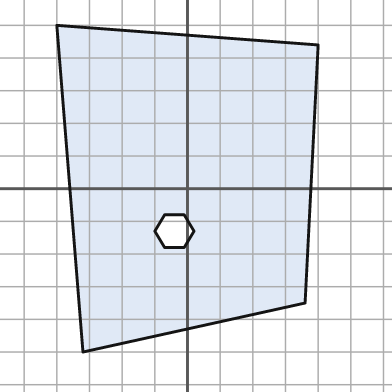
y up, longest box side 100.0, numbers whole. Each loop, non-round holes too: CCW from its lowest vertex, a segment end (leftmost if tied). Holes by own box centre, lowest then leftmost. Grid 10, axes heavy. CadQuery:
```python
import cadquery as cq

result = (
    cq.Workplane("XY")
    .moveTo(-32.0, -50.0)
    .lineTo(36.0, -35.0)
    .lineTo(40.0, 44.0)
    .lineTo(-40.0, 50.0)
    .close()
    .moveTo(-7.0, -18.0)
    .lineTo(-1.0, -18.0)
    .lineTo(2.0, -13.0)
    .lineTo(-1.0, -8.0)
    .lineTo(-7.0, -8.0)
    .lineTo(-10.0, -13.0)
    .close()
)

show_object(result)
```